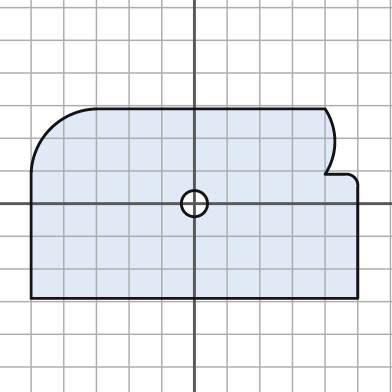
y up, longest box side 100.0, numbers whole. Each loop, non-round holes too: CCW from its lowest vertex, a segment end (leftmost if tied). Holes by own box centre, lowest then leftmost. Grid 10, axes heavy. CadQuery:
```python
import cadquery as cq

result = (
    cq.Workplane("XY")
    .moveTo(-50.0, -29.0)
    .lineTo(50.0, -29.0)
    .lineTo(50.0, 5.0)
    .threePointArc((49.0, 8.0), (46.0, 9.0))
    .lineTo(40.0, 9.0)
    .threePointArc((43.0, 19.0), (40.0, 29.0))
    .lineTo(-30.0, 29.0)
    .threePointArc((-44.0, 23.0), (-50.0, 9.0))
    .close()
    .moveTo(0.0, 0.0)
    .circle(4.0)
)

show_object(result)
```